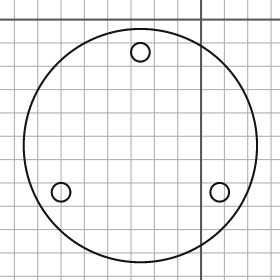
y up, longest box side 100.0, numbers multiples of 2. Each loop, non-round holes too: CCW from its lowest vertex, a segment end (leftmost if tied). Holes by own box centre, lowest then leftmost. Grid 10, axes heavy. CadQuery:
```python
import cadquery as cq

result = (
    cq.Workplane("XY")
    .moveTo(-26.0, -54.0)
    .circle(50.0)
    .moveTo(-60.0, -74.0)
    .circle(4.0)
    .moveTo(8.0, -74.0)
    .circle(4.0)
    .moveTo(-26.0, -14.0)
    .circle(4.0)
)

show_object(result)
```